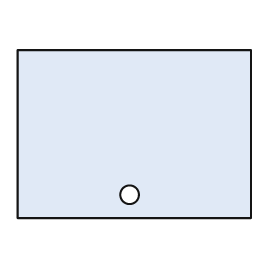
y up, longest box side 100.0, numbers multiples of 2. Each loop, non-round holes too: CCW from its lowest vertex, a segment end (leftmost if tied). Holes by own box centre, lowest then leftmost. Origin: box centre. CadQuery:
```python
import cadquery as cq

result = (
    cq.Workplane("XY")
    .moveTo(-50.0, -36.0)
    .lineTo(50.0, -36.0)
    .lineTo(50.0, 36.0)
    .lineTo(-50.0, 36.0)
    .close()
    .moveTo(-2.0, -26.0)
    .circle(4.0)
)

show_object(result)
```